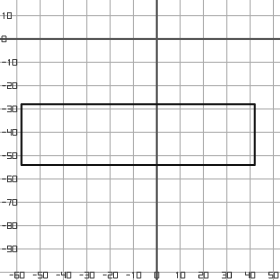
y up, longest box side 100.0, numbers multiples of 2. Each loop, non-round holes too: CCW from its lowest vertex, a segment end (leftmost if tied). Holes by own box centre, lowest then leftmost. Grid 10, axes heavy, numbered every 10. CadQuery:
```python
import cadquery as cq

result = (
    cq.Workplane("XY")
    .moveTo(-58.0, -54.0)
    .lineTo(42.0, -54.0)
    .lineTo(42.0, -28.0)
    .lineTo(-58.0, -28.0)
    .close()
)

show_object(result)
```